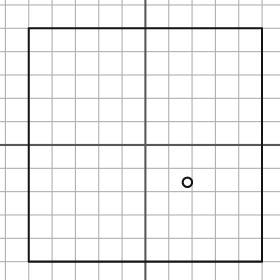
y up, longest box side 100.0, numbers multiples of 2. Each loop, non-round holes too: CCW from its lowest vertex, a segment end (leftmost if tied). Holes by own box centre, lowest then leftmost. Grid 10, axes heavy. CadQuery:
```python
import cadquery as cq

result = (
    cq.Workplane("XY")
    .moveTo(-50.0, -50.0)
    .lineTo(50.0, -50.0)
    .lineTo(50.0, 50.0)
    .lineTo(-50.0, 50.0)
    .close()
    .moveTo(18.0, -16.0)
    .circle(2.0)
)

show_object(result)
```